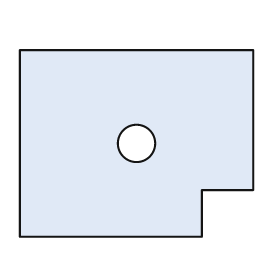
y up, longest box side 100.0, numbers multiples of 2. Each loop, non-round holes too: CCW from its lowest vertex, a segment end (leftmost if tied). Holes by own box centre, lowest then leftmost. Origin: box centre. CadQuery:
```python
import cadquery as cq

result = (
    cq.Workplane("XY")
    .moveTo(-50.0, -40.0)
    .lineTo(28.0, -40.0)
    .lineTo(28.0, -20.0)
    .lineTo(50.0, -20.0)
    .lineTo(50.0, 40.0)
    .lineTo(-50.0, 40.0)
    .close()
    .moveTo(0.0, 0.0)
    .circle(8.0)
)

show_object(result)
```